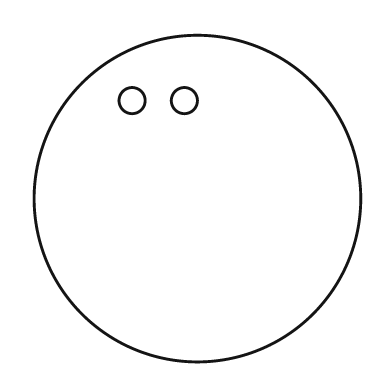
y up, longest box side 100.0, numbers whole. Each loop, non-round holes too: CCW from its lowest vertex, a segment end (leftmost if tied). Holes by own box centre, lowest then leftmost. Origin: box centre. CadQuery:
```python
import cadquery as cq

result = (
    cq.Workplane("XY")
    .moveTo(0.0, 0.0)
    .circle(50.0)
    .moveTo(-20.0, 30.0)
    .circle(4.0)
    .moveTo(-4.0, 30.0)
    .circle(4.0)
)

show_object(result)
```